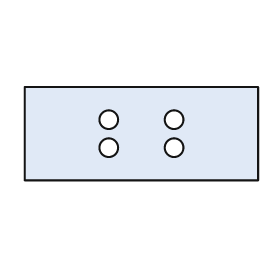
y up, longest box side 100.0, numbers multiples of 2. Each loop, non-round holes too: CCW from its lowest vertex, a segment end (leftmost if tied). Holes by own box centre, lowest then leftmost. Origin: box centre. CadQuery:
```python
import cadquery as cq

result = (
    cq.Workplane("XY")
    .moveTo(-50.0, -20.0)
    .lineTo(50.0, -20.0)
    .lineTo(50.0, 20.0)
    .lineTo(-50.0, 20.0)
    .close()
    .moveTo(-14.0, -6.0)
    .circle(4.0)
    .moveTo(14.0, -6.0)
    .circle(4.0)
    .moveTo(-14.0, 6.0)
    .circle(4.0)
    .moveTo(14.0, 6.0)
    .circle(4.0)
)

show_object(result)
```